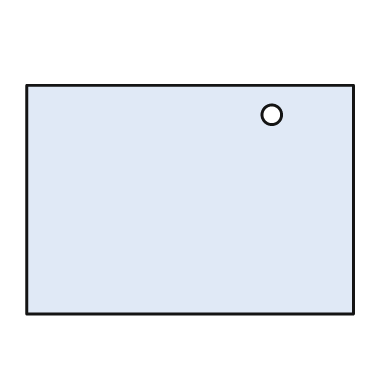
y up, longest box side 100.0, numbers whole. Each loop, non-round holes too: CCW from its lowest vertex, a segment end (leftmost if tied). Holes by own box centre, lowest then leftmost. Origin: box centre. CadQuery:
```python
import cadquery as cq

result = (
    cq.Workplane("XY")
    .moveTo(-50.0, -35.0)
    .lineTo(50.0, -35.0)
    .lineTo(50.0, 35.0)
    .lineTo(-50.0, 35.0)
    .close()
    .moveTo(25.0, 26.0)
    .circle(3.0)
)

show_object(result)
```